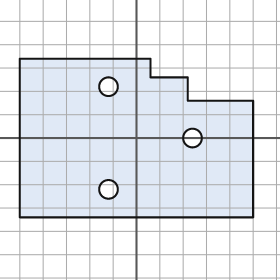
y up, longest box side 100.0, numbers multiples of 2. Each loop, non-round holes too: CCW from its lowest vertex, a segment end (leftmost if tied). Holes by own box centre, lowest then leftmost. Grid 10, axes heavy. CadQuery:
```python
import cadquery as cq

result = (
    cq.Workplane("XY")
    .moveTo(-50.0, -34.0)
    .lineTo(50.0, -34.0)
    .lineTo(50.0, 16.0)
    .lineTo(22.0, 16.0)
    .lineTo(22.0, 26.0)
    .lineTo(6.0, 26.0)
    .lineTo(6.0, 34.0)
    .lineTo(-50.0, 34.0)
    .close()
    .moveTo(-12.0, -22.0)
    .circle(4.0)
    .moveTo(24.0, 0.0)
    .circle(4.0)
    .moveTo(-12.0, 22.0)
    .circle(4.0)
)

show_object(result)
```